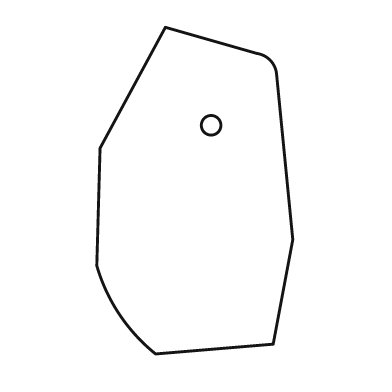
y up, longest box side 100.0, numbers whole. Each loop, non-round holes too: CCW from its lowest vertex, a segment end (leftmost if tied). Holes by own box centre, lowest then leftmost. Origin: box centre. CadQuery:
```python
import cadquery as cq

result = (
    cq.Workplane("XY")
    .moveTo(-12.0, -50.0)
    .lineTo(24.0, -47.0)
    .lineTo(30.0, -15.0)
    .lineTo(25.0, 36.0)
    .threePointArc((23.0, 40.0), (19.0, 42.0))
    .lineTo(-9.0, 50.0)
    .lineTo(-29.0, 13.0)
    .lineTo(-30.0, -23.0)
    .threePointArc((-23.0, -38.0), (-12.0, -50.0))
    .close()
    .moveTo(5.0, 20.0)
    .circle(3.0)
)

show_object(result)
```